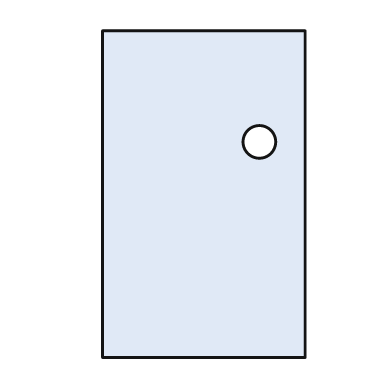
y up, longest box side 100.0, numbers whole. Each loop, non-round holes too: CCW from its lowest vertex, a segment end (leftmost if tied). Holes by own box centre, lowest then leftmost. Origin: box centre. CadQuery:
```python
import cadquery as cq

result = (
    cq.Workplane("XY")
    .moveTo(-31.0, -50.0)
    .lineTo(31.0, -50.0)
    .lineTo(31.0, 50.0)
    .lineTo(-31.0, 50.0)
    .close()
    .moveTo(17.0, 16.0)
    .circle(5.0)
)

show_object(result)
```